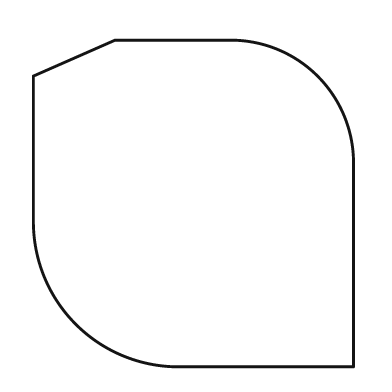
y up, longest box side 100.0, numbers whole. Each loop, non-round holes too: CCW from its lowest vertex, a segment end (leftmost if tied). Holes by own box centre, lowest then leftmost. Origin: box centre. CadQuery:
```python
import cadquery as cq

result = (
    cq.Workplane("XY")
    .moveTo(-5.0, -50.0)
    .lineTo(49.0, -50.0)
    .lineTo(49.0, 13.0)
    .threePointArc((38.0, 39.0), (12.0, 50.0))
    .lineTo(-24.0, 50.0)
    .lineTo(-49.0, 39.0)
    .lineTo(-49.0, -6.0)
    .threePointArc((-36.0, -37.0), (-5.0, -50.0))
    .close()
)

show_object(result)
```